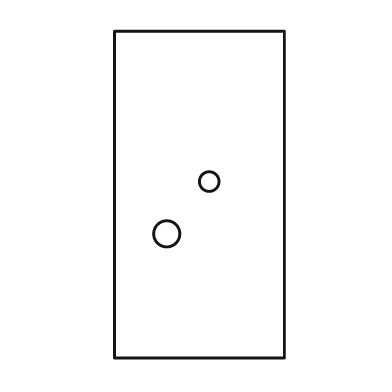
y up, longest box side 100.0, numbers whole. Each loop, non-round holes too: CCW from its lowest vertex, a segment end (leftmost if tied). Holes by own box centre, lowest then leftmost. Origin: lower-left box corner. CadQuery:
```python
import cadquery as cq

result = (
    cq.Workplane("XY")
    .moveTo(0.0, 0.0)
    .lineTo(52.0, 0.0)
    .lineTo(52.0, 100.0)
    .lineTo(0.0, 100.0)
    .close()
    .moveTo(16.0, 38.0)
    .circle(4.0)
    .moveTo(29.0, 54.0)
    .circle(3.0)
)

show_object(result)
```